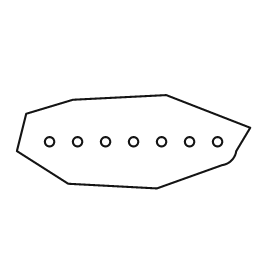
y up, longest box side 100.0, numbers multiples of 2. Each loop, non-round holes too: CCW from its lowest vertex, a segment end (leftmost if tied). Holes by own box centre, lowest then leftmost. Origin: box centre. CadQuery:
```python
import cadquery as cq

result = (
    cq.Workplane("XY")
    .moveTo(10.0, -20.0)
    .lineTo(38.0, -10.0)
    .threePointArc((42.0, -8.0), (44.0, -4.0))
    .lineTo(50.0, 6.0)
    .lineTo(14.0, 20.0)
    .lineTo(-26.0, 18.0)
    .lineTo(-46.0, 12.0)
    .lineTo(-50.0, -4.0)
    .lineTo(-28.0, -18.0)
    .close()
    .moveTo(-36.0, 0.0)
    .circle(2.0)
    .moveTo(-24.0, 0.0)
    .circle(2.0)
    .moveTo(-12.0, 0.0)
    .circle(2.0)
    .moveTo(0.0, 0.0)
    .circle(2.0)
    .moveTo(12.0, 0.0)
    .circle(2.0)
    .moveTo(24.0, 0.0)
    .circle(2.0)
    .moveTo(36.0, 0.0)
    .circle(2.0)
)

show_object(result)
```